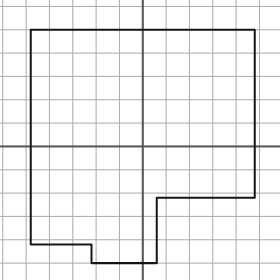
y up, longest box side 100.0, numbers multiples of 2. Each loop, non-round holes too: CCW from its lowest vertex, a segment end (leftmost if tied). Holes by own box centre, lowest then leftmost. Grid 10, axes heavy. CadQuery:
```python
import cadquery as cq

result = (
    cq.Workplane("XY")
    .moveTo(-22.0, -50.0)
    .lineTo(6.0, -50.0)
    .lineTo(6.0, -22.0)
    .lineTo(48.0, -22.0)
    .lineTo(48.0, 50.0)
    .lineTo(-48.0, 50.0)
    .lineTo(-48.0, -42.0)
    .lineTo(-22.0, -42.0)
    .close()
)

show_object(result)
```